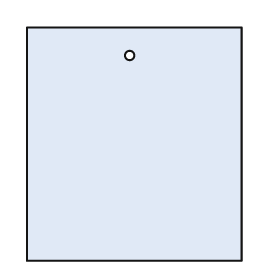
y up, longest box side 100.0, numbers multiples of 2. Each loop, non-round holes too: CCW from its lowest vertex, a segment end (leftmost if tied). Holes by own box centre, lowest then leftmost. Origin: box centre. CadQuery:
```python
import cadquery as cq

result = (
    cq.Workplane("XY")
    .moveTo(-46.0, -50.0)
    .lineTo(46.0, -50.0)
    .lineTo(46.0, 50.0)
    .lineTo(-46.0, 50.0)
    .close()
    .moveTo(-2.0, 38.0)
    .circle(2.0)
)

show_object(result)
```